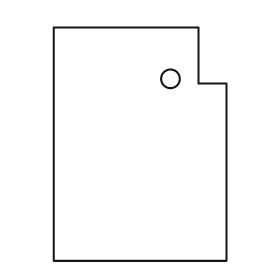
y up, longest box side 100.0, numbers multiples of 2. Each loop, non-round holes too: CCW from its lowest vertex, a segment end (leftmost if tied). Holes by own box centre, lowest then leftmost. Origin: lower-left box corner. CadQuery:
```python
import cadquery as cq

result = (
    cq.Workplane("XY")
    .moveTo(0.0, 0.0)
    .lineTo(74.0, 0.0)
    .lineTo(74.0, 76.0)
    .lineTo(62.0, 76.0)
    .lineTo(62.0, 100.0)
    .lineTo(0.0, 100.0)
    .close()
    .moveTo(50.0, 78.0)
    .circle(4.0)
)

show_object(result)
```